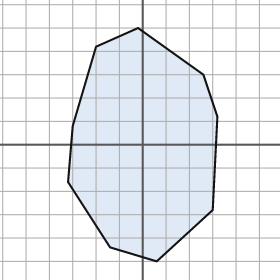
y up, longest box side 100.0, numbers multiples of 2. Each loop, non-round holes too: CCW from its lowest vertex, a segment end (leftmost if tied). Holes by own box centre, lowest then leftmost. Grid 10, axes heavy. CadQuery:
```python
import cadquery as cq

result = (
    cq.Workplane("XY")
    .moveTo(6.0, -50.0)
    .lineTo(30.0, -28.0)
    .lineTo(32.0, 12.0)
    .lineTo(26.0, 30.0)
    .lineTo(-2.0, 50.0)
    .lineTo(-20.0, 42.0)
    .lineTo(-30.0, 8.0)
    .lineTo(-32.0, -16.0)
    .lineTo(-14.0, -44.0)
    .close()
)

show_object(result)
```